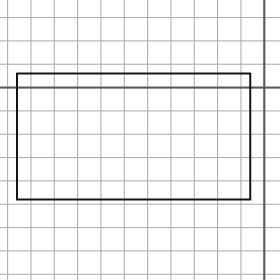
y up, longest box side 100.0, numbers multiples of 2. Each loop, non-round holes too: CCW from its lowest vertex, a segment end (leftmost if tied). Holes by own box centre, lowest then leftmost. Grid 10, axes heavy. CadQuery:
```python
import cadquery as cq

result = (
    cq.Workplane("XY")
    .moveTo(-106.0, -48.0)
    .lineTo(-6.0, -48.0)
    .lineTo(-6.0, 6.0)
    .lineTo(-106.0, 6.0)
    .close()
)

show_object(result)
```